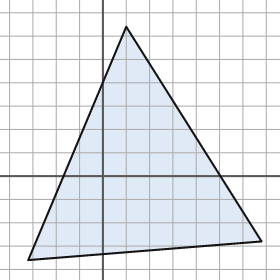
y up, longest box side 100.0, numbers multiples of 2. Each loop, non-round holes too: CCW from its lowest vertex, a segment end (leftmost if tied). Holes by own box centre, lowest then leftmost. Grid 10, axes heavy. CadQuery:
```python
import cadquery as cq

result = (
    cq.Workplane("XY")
    .moveTo(-32.0, -36.0)
    .lineTo(68.0, -28.0)
    .lineTo(10.0, 64.0)
    .close()
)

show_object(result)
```